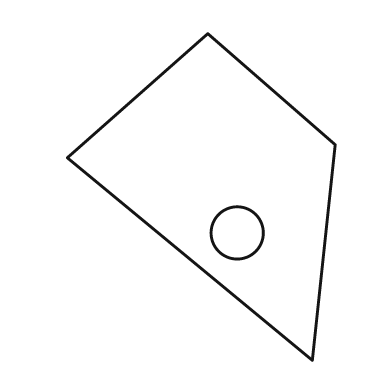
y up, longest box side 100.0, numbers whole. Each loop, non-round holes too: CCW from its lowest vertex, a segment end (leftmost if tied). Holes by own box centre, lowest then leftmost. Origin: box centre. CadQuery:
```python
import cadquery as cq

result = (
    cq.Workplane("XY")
    .moveTo(34.0, -50.0)
    .lineTo(41.0, 16.0)
    .lineTo(2.0, 50.0)
    .lineTo(-41.0, 12.0)
    .close()
    .moveTo(11.0, -11.0)
    .circle(8.0)
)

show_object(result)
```